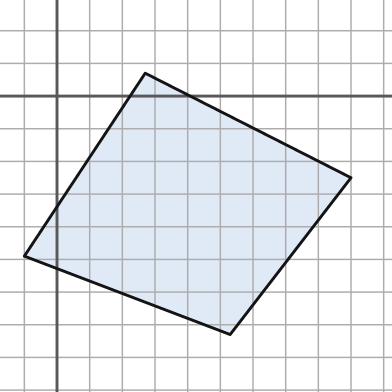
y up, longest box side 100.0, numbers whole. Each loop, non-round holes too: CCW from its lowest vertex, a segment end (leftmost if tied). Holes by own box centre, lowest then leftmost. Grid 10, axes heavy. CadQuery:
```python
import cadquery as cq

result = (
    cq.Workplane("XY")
    .moveTo(53.0, -73.0)
    .lineTo(90.0, -25.0)
    .lineTo(27.0, 7.0)
    .lineTo(-10.0, -49.0)
    .close()
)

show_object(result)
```